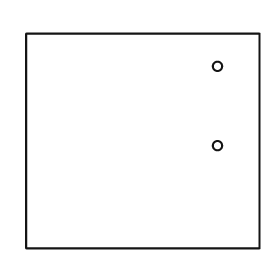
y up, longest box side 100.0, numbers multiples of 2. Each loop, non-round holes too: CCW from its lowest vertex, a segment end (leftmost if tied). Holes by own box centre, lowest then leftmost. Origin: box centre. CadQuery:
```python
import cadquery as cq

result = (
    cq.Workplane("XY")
    .moveTo(-50.0, -46.0)
    .lineTo(50.0, -46.0)
    .lineTo(50.0, 46.0)
    .lineTo(-50.0, 46.0)
    .close()
    .moveTo(32.0, -2.0)
    .circle(2.0)
    .moveTo(32.0, 32.0)
    .circle(2.0)
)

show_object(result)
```